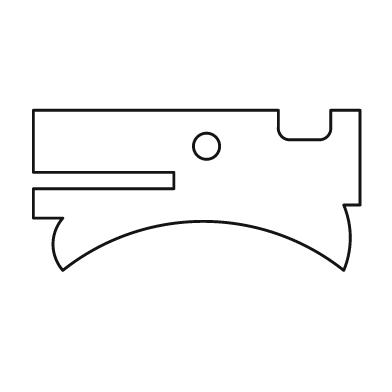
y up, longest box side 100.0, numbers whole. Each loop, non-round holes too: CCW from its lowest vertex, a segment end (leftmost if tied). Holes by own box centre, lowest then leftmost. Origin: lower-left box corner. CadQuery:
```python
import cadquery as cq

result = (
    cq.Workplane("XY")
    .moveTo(9.0, 0.0)
    .threePointArc((52.0, 15.0), (95.0, 0.0))
    .threePointArc((97.0, 10.0), (95.0, 20.0))
    .lineTo(100.0, 20.0)
    .lineTo(100.0, 49.0)
    .lineTo(91.0, 49.0)
    .lineTo(91.0, 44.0)
    .threePointArc((90.0, 41.0), (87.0, 40.0))
    .lineTo(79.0, 40.0)
    .threePointArc((76.0, 41.0), (75.0, 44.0))
    .lineTo(75.0, 49.0)
    .lineTo(0.0, 49.0)
    .lineTo(0.0, 30.0)
    .lineTo(43.0, 30.0)
    .lineTo(43.0, 25.0)
    .lineTo(0.0, 25.0)
    .lineTo(0.0, 16.0)
    .lineTo(9.0, 16.0)
    .threePointArc((6.0, 8.0), (9.0, 0.0))
    .close()
    .moveTo(53.0, 38.0)
    .circle(4.0)
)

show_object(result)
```